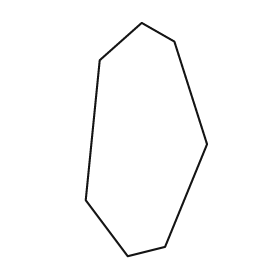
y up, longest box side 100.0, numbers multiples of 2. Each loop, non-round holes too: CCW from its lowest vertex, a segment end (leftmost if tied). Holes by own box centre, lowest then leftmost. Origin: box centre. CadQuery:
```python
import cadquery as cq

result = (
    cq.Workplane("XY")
    .moveTo(-8.0, -50.0)
    .lineTo(8.0, -46.0)
    .lineTo(26.0, -2.0)
    .lineTo(12.0, 42.0)
    .lineTo(-2.0, 50.0)
    .lineTo(-20.0, 34.0)
    .lineTo(-26.0, -26.0)
    .close()
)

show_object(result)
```